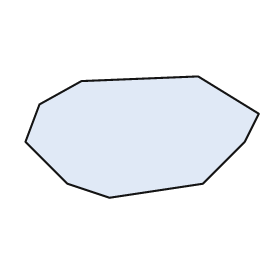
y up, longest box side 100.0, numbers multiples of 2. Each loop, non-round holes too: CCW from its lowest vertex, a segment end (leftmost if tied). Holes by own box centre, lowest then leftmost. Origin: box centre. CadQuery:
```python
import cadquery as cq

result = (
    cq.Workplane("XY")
    .moveTo(-14.0, -26.0)
    .lineTo(26.0, -20.0)
    .lineTo(44.0, -2.0)
    .lineTo(50.0, 10.0)
    .lineTo(24.0, 26.0)
    .lineTo(-26.0, 24.0)
    .lineTo(-44.0, 14.0)
    .lineTo(-50.0, -2.0)
    .lineTo(-32.0, -20.0)
    .close()
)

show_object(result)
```